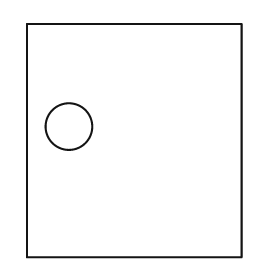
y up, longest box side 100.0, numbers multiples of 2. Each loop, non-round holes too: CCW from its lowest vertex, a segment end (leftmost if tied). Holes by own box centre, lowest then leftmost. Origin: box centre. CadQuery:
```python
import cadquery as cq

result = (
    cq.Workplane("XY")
    .moveTo(-46.0, -50.0)
    .lineTo(46.0, -50.0)
    .lineTo(46.0, 50.0)
    .lineTo(-46.0, 50.0)
    .close()
    .moveTo(-28.0, 6.0)
    .circle(10.0)
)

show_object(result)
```